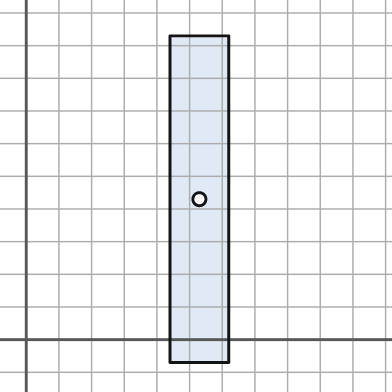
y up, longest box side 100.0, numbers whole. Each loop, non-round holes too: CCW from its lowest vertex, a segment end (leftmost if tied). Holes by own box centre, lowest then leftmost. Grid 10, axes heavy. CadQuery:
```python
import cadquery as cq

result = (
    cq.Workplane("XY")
    .moveTo(44.0, -7.0)
    .lineTo(62.0, -7.0)
    .lineTo(62.0, 93.0)
    .lineTo(44.0, 93.0)
    .close()
    .moveTo(53.0, 43.0)
    .circle(2.0)
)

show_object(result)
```